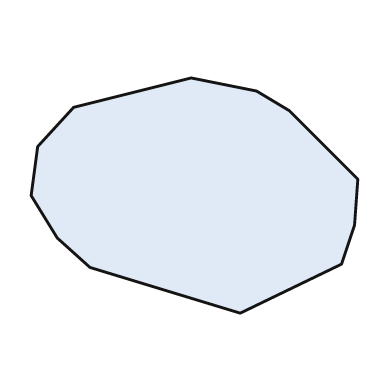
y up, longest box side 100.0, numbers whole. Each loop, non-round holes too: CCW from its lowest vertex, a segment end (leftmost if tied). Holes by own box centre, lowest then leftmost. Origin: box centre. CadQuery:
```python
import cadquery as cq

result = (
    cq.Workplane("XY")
    .moveTo(14.0, -36.0)
    .lineTo(45.0, -21.0)
    .lineTo(49.0, -9.0)
    .lineTo(50.0, 5.0)
    .lineTo(29.0, 26.0)
    .lineTo(19.0, 32.0)
    .lineTo(-1.0, 36.0)
    .lineTo(-37.0, 27.0)
    .lineTo(-48.0, 15.0)
    .lineTo(-50.0, 0.0)
    .lineTo(-42.0, -13.0)
    .lineTo(-32.0, -22.0)
    .close()
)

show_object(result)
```